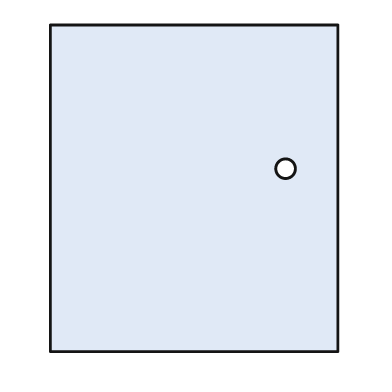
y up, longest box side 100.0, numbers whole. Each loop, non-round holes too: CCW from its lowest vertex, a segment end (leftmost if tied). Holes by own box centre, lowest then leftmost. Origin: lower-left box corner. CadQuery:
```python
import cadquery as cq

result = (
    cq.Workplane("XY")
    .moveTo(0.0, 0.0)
    .lineTo(88.0, 0.0)
    .lineTo(88.0, 100.0)
    .lineTo(0.0, 100.0)
    .close()
    .moveTo(72.0, 56.0)
    .circle(3.0)
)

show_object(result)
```